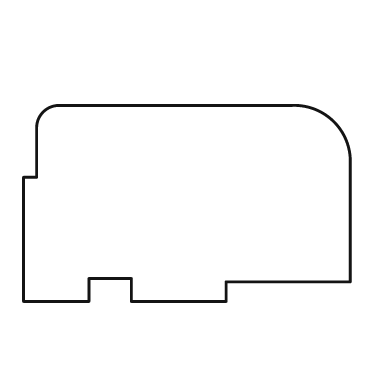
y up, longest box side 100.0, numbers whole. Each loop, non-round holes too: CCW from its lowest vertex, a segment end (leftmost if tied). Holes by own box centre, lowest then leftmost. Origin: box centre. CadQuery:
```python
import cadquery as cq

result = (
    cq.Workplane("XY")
    .moveTo(-50.0, -30.0)
    .lineTo(-30.0, -30.0)
    .lineTo(-30.0, -23.0)
    .lineTo(-17.0, -23.0)
    .lineTo(-17.0, -30.0)
    .lineTo(12.0, -30.0)
    .lineTo(12.0, -24.0)
    .lineTo(50.0, -24.0)
    .lineTo(50.0, 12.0)
    .threePointArc((45.0, 25.0), (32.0, 30.0))
    .lineTo(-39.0, 30.0)
    .threePointArc((-44.0, 28.0), (-46.0, 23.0))
    .lineTo(-46.0, 8.0)
    .lineTo(-50.0, 8.0)
    .close()
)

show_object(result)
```